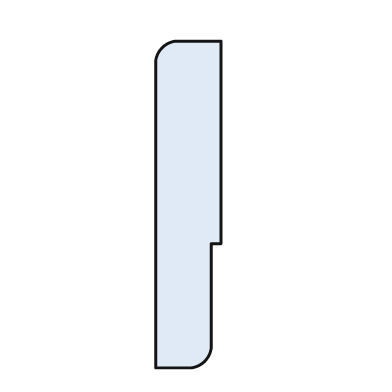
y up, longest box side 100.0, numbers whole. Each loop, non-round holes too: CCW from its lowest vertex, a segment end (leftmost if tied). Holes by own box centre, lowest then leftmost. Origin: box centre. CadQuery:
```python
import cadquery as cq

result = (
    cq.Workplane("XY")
    .moveTo(-10.0, -50.0)
    .lineTo(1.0, -50.0)
    .threePointArc((5.0, -48.0), (7.0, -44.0))
    .lineTo(7.0, -12.0)
    .lineTo(10.0, -12.0)
    .lineTo(10.0, 50.0)
    .lineTo(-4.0, 50.0)
    .threePointArc((-8.0, 48.0), (-10.0, 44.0))
    .close()
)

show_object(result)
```